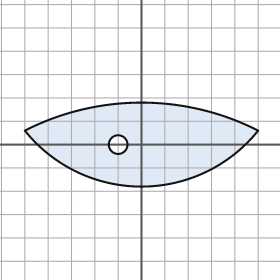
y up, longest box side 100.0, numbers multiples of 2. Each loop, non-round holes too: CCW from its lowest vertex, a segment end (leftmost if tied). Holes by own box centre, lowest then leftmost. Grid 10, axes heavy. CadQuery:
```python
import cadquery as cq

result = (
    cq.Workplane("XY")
    .moveTo(-50.0, 6.0)
    .threePointArc((0.0, -18.0), (50.0, 6.0))
    .threePointArc((0.0, 18.0), (-50.0, 6.0))
    .close()
    .moveTo(-10.0, 0.0)
    .circle(4.0)
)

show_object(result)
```